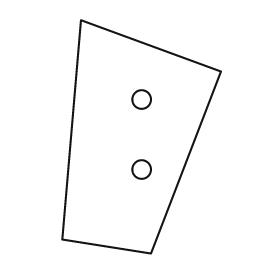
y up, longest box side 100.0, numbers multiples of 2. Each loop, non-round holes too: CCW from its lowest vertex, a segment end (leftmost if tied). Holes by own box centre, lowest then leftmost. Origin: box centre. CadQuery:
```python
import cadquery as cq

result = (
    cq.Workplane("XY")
    .moveTo(4.0, -50.0)
    .lineTo(34.0, 28.0)
    .lineTo(-26.0, 50.0)
    .lineTo(-34.0, -44.0)
    .close()
    .moveTo(0.0, -14.0)
    .circle(4.0)
    .moveTo(0.0, 16.0)
    .circle(4.0)
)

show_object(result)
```